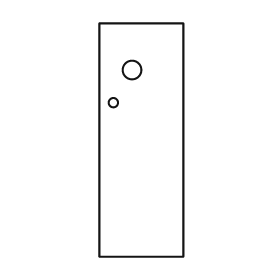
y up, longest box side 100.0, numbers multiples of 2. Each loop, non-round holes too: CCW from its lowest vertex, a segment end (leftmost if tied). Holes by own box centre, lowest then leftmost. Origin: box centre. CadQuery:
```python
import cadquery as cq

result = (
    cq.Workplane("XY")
    .moveTo(-18.0, -50.0)
    .lineTo(18.0, -50.0)
    .lineTo(18.0, 50.0)
    .lineTo(-18.0, 50.0)
    .close()
    .moveTo(-12.0, 16.0)
    .circle(2.0)
    .moveTo(-4.0, 30.0)
    .circle(4.0)
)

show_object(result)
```